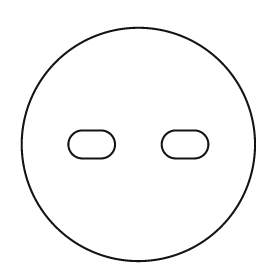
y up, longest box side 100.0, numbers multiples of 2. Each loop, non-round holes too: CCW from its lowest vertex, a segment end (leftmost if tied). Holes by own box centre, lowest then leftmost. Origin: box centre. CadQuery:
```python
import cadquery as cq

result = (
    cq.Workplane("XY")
    .moveTo(0.0, 0.0)
    .circle(50.0)
    .moveTo(-24.0, -6.0)
    .lineTo(-16.0, -6.0)
    .threePointArc((-10.0, 0.0), (-16.0, 6.0))
    .lineTo(-24.0, 6.0)
    .threePointArc((-30.0, 0.0), (-24.0, -6.0))
    .close()
    .moveTo(16.0, -6.0)
    .lineTo(24.0, -6.0)
    .threePointArc((30.0, 0.0), (24.0, 6.0))
    .lineTo(16.0, 6.0)
    .threePointArc((10.0, 0.0), (16.0, -6.0))
    .close()
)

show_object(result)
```